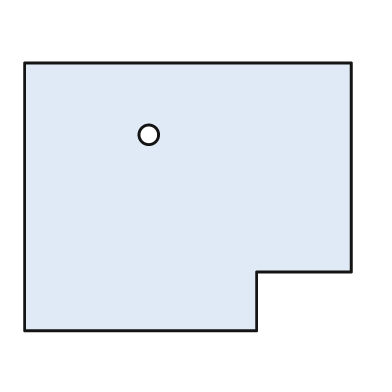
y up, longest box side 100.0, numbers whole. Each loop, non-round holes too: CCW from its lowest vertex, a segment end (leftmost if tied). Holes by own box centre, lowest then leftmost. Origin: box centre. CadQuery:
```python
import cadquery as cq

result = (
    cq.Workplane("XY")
    .moveTo(-50.0, -41.0)
    .lineTo(21.0, -41.0)
    .lineTo(21.0, -23.0)
    .lineTo(50.0, -23.0)
    .lineTo(50.0, 41.0)
    .lineTo(-50.0, 41.0)
    .close()
    .moveTo(-12.0, 19.0)
    .circle(3.0)
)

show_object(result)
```